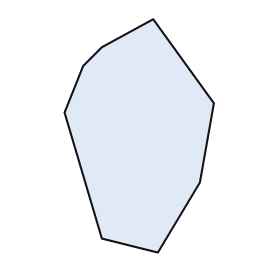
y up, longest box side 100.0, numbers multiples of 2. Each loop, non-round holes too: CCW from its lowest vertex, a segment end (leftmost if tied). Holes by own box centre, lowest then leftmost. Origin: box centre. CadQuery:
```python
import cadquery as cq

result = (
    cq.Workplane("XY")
    .moveTo(8.0, -50.0)
    .lineTo(26.0, -20.0)
    .lineTo(32.0, 14.0)
    .lineTo(6.0, 50.0)
    .lineTo(-16.0, 38.0)
    .lineTo(-24.0, 30.0)
    .lineTo(-32.0, 10.0)
    .lineTo(-16.0, -44.0)
    .close()
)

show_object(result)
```